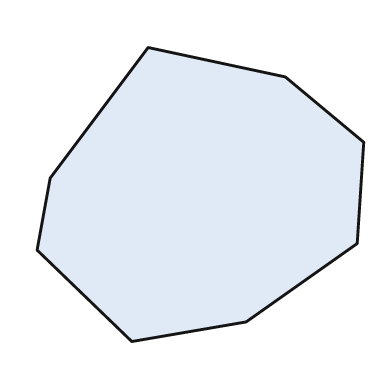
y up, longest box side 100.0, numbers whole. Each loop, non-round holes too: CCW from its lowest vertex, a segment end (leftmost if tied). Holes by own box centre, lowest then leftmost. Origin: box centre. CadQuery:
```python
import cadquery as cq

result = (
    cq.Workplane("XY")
    .moveTo(-21.0, -45.0)
    .lineTo(14.0, -39.0)
    .lineTo(48.0, -15.0)
    .lineTo(50.0, 16.0)
    .lineTo(26.0, 36.0)
    .lineTo(-16.0, 45.0)
    .lineTo(-46.0, 5.0)
    .lineTo(-50.0, -17.0)
    .close()
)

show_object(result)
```